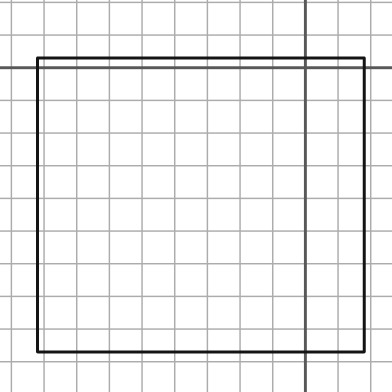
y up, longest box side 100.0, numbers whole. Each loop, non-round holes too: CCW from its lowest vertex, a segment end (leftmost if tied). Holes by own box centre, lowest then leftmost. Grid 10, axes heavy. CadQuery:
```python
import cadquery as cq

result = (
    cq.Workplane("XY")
    .moveTo(-82.0, -87.0)
    .lineTo(18.0, -87.0)
    .lineTo(18.0, 3.0)
    .lineTo(-82.0, 3.0)
    .close()
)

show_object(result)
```